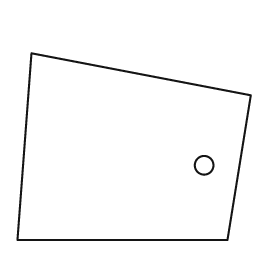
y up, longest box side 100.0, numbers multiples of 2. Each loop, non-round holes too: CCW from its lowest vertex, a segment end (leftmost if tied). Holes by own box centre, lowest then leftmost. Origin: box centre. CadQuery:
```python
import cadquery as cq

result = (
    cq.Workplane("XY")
    .moveTo(-50.0, -40.0)
    .lineTo(40.0, -40.0)
    .lineTo(50.0, 22.0)
    .lineTo(-44.0, 40.0)
    .close()
    .moveTo(30.0, -8.0)
    .circle(4.0)
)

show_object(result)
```